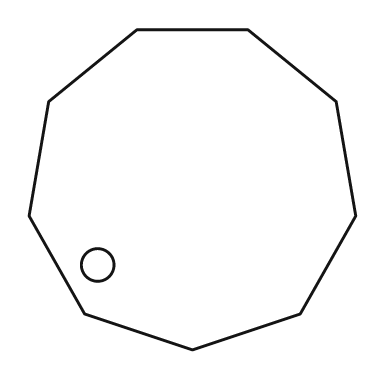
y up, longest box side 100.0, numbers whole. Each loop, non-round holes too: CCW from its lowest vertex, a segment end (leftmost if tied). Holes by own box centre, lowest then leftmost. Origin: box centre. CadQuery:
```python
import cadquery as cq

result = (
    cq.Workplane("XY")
    .moveTo(0.0, -49.0)
    .lineTo(33.0, -38.0)
    .lineTo(50.0, -8.0)
    .lineTo(44.0, 27.0)
    .lineTo(17.0, 49.0)
    .lineTo(-17.0, 49.0)
    .lineTo(-44.0, 27.0)
    .lineTo(-50.0, -8.0)
    .lineTo(-33.0, -38.0)
    .close()
    .moveTo(-29.0, -23.0)
    .circle(5.0)
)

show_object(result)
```